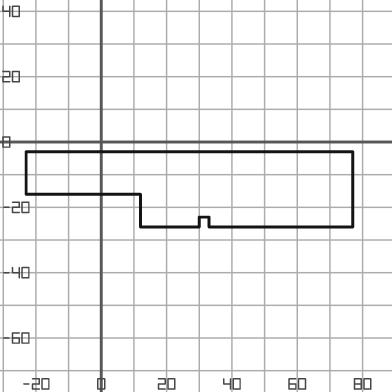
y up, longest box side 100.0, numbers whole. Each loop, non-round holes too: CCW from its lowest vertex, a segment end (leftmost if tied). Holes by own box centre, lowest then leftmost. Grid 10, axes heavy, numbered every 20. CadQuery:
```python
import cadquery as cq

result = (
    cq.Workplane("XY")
    .moveTo(12.0, -26.0)
    .lineTo(30.0, -26.0)
    .lineTo(30.0, -23.0)
    .lineTo(33.0, -23.0)
    .lineTo(33.0, -26.0)
    .lineTo(77.0, -26.0)
    .lineTo(77.0, -3.0)
    .lineTo(-23.0, -3.0)
    .lineTo(-23.0, -16.0)
    .lineTo(12.0, -16.0)
    .close()
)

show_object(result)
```